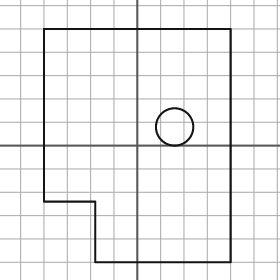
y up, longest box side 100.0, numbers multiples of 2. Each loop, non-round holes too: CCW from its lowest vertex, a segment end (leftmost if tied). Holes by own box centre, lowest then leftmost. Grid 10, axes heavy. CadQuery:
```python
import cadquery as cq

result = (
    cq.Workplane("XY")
    .moveTo(-18.0, -50.0)
    .lineTo(40.0, -50.0)
    .lineTo(40.0, 50.0)
    .lineTo(-40.0, 50.0)
    .lineTo(-40.0, -24.0)
    .lineTo(-18.0, -24.0)
    .close()
    .moveTo(16.0, 8.0)
    .circle(8.0)
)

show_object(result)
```